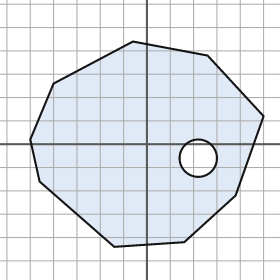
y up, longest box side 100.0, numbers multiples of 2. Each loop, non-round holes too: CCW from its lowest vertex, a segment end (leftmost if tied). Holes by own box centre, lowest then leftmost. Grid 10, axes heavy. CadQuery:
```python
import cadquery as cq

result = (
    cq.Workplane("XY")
    .moveTo(-14.0, -44.0)
    .lineTo(16.0, -42.0)
    .lineTo(38.0, -22.0)
    .lineTo(50.0, 12.0)
    .lineTo(26.0, 38.0)
    .lineTo(-6.0, 44.0)
    .lineTo(-40.0, 26.0)
    .lineTo(-50.0, 2.0)
    .lineTo(-46.0, -16.0)
    .close()
    .moveTo(22.0, -6.0)
    .circle(8.0)
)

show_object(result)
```